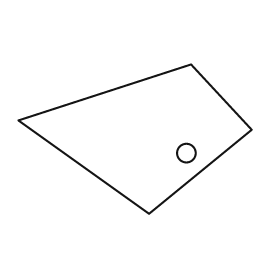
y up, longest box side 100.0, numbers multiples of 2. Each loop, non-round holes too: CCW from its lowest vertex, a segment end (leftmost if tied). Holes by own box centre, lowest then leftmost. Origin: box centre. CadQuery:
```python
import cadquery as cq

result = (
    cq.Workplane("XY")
    .moveTo(6.0, -32.0)
    .lineTo(50.0, 4.0)
    .lineTo(24.0, 32.0)
    .lineTo(-50.0, 8.0)
    .close()
    .moveTo(22.0, -6.0)
    .circle(4.0)
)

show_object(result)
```